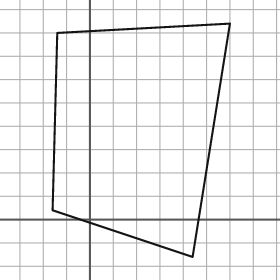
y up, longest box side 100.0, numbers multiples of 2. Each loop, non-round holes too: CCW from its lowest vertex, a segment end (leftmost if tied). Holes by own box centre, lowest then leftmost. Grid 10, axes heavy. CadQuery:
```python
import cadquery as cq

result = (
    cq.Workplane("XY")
    .moveTo(44.0, -16.0)
    .lineTo(60.0, 84.0)
    .lineTo(-14.0, 80.0)
    .lineTo(-16.0, 4.0)
    .close()
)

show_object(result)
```